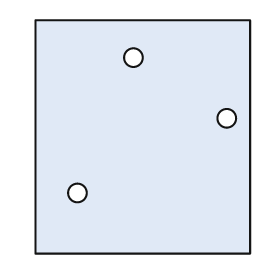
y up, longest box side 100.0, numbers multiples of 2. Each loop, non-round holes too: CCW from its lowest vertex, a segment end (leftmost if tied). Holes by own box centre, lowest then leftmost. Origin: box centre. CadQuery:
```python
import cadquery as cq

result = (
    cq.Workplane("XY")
    .moveTo(-46.0, -50.0)
    .lineTo(46.0, -50.0)
    .lineTo(46.0, 50.0)
    .lineTo(-46.0, 50.0)
    .close()
    .moveTo(-28.0, -24.0)
    .circle(4.0)
    .moveTo(36.0, 8.0)
    .circle(4.0)
    .moveTo(-4.0, 34.0)
    .circle(4.0)
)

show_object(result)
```